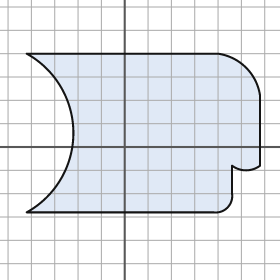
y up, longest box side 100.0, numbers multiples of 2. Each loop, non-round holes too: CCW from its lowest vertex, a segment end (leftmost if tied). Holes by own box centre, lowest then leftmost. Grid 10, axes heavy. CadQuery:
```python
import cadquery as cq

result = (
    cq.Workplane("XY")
    .moveTo(-42.0, -28.0)
    .lineTo(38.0, -28.0)
    .threePointArc((44.0, -26.0), (46.0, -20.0))
    .lineTo(46.0, -8.0)
    .threePointArc((52.0, -10.0), (58.0, -8.0))
    .lineTo(58.0, 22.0)
    .threePointArc((52.0, 34.0), (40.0, 40.0))
    .lineTo(-42.0, 40.0)
    .threePointArc((-22.0, 6.0), (-42.0, -28.0))
    .close()
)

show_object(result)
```